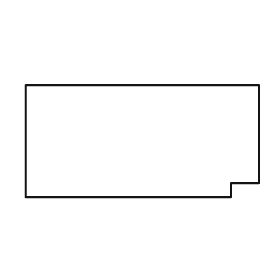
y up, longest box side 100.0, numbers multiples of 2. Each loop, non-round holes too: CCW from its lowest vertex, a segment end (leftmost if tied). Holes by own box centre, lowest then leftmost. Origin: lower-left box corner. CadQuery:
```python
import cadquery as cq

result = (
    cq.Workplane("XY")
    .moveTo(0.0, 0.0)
    .lineTo(88.0, 0.0)
    .lineTo(88.0, 6.0)
    .lineTo(100.0, 6.0)
    .lineTo(100.0, 48.0)
    .lineTo(0.0, 48.0)
    .close()
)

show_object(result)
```